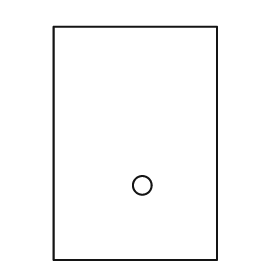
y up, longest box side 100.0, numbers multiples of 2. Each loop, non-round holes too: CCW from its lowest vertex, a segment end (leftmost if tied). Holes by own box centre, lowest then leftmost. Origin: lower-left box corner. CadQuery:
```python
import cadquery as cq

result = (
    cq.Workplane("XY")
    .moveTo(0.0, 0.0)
    .lineTo(70.0, 0.0)
    .lineTo(70.0, 100.0)
    .lineTo(0.0, 100.0)
    .close()
    .moveTo(38.0, 32.0)
    .circle(4.0)
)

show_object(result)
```